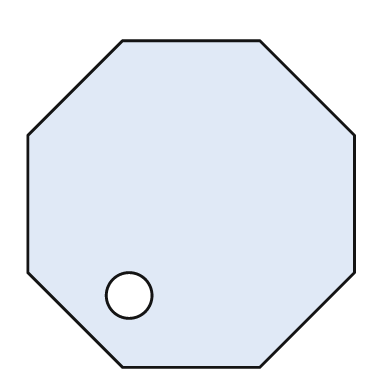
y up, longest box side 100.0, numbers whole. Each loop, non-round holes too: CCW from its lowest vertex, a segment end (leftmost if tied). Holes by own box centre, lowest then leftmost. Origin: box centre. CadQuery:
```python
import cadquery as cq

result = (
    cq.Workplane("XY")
    .moveTo(-21.0, -50.0)
    .lineTo(21.0, -50.0)
    .lineTo(50.0, -21.0)
    .lineTo(50.0, 21.0)
    .lineTo(21.0, 50.0)
    .lineTo(-21.0, 50.0)
    .lineTo(-50.0, 21.0)
    .lineTo(-50.0, -21.0)
    .close()
    .moveTo(-19.0, -28.0)
    .circle(7.0)
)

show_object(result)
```